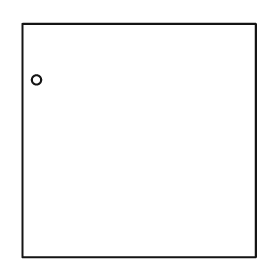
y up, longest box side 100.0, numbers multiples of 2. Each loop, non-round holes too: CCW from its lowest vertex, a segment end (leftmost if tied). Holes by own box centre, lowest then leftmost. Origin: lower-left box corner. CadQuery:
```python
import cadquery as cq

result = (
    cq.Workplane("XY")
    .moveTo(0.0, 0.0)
    .lineTo(100.0, 0.0)
    .lineTo(100.0, 100.0)
    .lineTo(0.0, 100.0)
    .close()
    .moveTo(6.0, 76.0)
    .circle(2.0)
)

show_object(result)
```